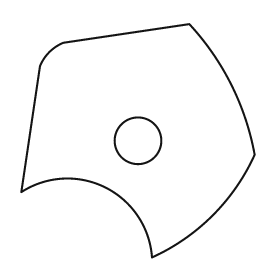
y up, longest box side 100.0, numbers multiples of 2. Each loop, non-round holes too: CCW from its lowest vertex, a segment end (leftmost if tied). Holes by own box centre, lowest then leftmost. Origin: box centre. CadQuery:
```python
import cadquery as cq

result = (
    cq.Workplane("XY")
    .moveTo(6.0, -50.0)
    .threePointArc((32.0, -32.0), (50.0, -6.0))
    .threePointArc((40.0, 24.0), (22.0, 50.0))
    .lineTo(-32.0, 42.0)
    .threePointArc((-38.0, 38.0), (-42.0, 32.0))
    .lineTo(-50.0, -22.0)
    .threePointArc((-14.0, -20.0), (6.0, -50.0))
    .close()
    .moveTo(0.0, 0.0)
    .circle(10.0)
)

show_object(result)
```